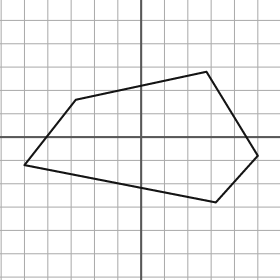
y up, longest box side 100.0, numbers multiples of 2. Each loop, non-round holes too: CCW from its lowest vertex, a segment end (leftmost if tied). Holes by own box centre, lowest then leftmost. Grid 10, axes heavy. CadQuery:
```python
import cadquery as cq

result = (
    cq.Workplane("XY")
    .moveTo(32.0, -28.0)
    .lineTo(50.0, -8.0)
    .lineTo(28.0, 28.0)
    .lineTo(-28.0, 16.0)
    .lineTo(-50.0, -12.0)
    .close()
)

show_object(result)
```